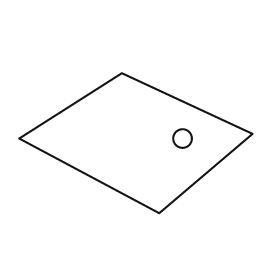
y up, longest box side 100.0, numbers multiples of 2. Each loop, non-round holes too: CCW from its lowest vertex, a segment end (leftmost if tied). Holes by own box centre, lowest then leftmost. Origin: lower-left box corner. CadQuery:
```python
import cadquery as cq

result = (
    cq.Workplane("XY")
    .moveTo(60.0, 0.0)
    .lineTo(100.0, 34.0)
    .lineTo(44.0, 60.0)
    .lineTo(0.0, 32.0)
    .close()
    .moveTo(70.0, 32.0)
    .circle(4.0)
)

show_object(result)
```